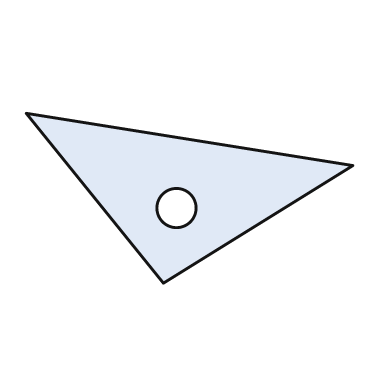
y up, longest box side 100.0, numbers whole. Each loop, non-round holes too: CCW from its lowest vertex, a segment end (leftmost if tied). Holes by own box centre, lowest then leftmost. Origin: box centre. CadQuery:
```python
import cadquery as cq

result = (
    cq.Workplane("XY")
    .moveTo(-8.0, -26.0)
    .lineTo(50.0, 10.0)
    .lineTo(-50.0, 26.0)
    .close()
    .moveTo(-4.0, -3.0)
    .circle(6.0)
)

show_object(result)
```